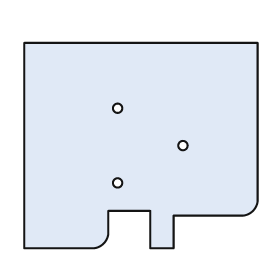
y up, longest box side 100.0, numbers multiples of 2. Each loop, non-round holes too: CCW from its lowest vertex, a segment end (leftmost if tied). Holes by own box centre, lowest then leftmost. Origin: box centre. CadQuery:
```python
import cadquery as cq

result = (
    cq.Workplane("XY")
    .moveTo(-50.0, -44.0)
    .lineTo(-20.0, -44.0)
    .threePointArc((-16.0, -42.0), (-14.0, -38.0))
    .lineTo(-14.0, -28.0)
    .lineTo(4.0, -28.0)
    .lineTo(4.0, -44.0)
    .lineTo(14.0, -44.0)
    .lineTo(14.0, -30.0)
    .lineTo(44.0, -30.0)
    .threePointArc((48.0, -28.0), (50.0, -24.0))
    .lineTo(50.0, 44.0)
    .lineTo(-50.0, 44.0)
    .close()
    .moveTo(-10.0, -16.0)
    .circle(2.0)
    .moveTo(18.0, 0.0)
    .circle(2.0)
    .moveTo(-10.0, 16.0)
    .circle(2.0)
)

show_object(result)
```